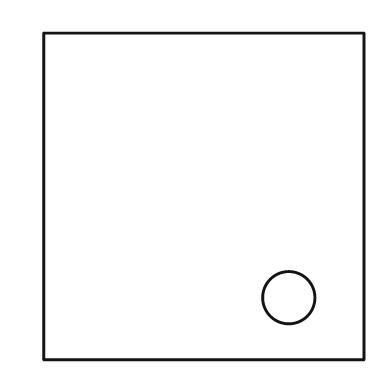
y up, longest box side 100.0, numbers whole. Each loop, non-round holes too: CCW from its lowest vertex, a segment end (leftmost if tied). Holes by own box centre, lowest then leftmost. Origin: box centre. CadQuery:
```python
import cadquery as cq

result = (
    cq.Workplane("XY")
    .moveTo(-49.0, -50.0)
    .lineTo(49.0, -50.0)
    .lineTo(49.0, 50.0)
    .lineTo(-49.0, 50.0)
    .close()
    .moveTo(26.0, -31.0)
    .circle(8.0)
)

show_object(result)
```